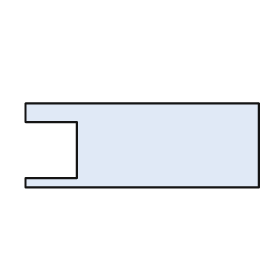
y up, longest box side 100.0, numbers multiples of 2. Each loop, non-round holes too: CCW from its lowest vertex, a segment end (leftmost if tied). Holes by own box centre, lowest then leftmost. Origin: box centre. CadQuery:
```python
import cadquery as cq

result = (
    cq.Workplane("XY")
    .moveTo(-50.0, -18.0)
    .lineTo(50.0, -18.0)
    .lineTo(50.0, 18.0)
    .lineTo(-50.0, 18.0)
    .lineTo(-50.0, 10.0)
    .lineTo(-28.0, 10.0)
    .lineTo(-28.0, -14.0)
    .lineTo(-50.0, -14.0)
    .close()
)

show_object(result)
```